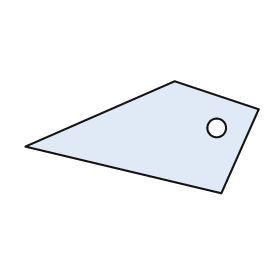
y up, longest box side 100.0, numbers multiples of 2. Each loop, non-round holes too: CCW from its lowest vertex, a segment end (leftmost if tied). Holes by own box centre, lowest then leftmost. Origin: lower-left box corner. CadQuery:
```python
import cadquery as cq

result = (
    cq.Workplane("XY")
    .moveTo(84.0, 0.0)
    .lineTo(100.0, 36.0)
    .lineTo(64.0, 48.0)
    .lineTo(0.0, 20.0)
    .close()
    .moveTo(82.0, 28.0)
    .circle(4.0)
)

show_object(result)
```